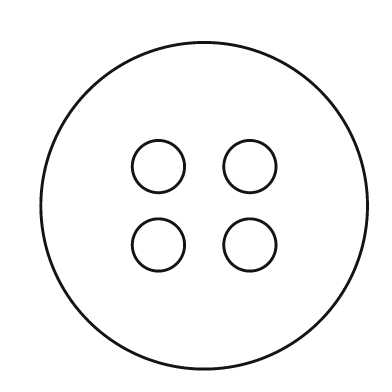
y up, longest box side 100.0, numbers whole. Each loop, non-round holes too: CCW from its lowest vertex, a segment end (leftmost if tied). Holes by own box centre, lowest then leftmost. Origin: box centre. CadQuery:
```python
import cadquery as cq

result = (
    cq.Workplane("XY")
    .moveTo(0.0, 0.0)
    .circle(50.0)
    .moveTo(-14.0, -12.0)
    .circle(8.0)
    .moveTo(14.0, -12.0)
    .circle(8.0)
    .moveTo(-14.0, 12.0)
    .circle(8.0)
    .moveTo(14.0, 12.0)
    .circle(8.0)
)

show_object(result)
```